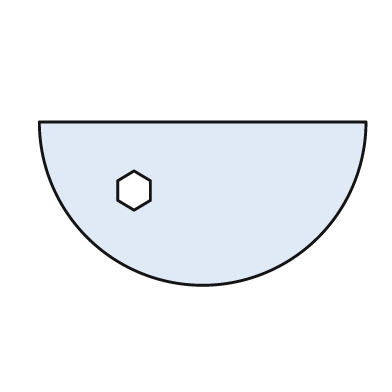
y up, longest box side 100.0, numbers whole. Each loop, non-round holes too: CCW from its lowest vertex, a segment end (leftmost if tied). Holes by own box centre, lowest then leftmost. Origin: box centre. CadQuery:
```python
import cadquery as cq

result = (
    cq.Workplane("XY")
    .moveTo(-50.0, 25.0)
    .threePointArc((0.0, -25.0), (50.0, 25.0))
    .close()
    .moveTo(-21.0, -2.0)
    .lineTo(-16.0, 1.0)
    .lineTo(-16.0, 7.0)
    .lineTo(-21.0, 10.0)
    .lineTo(-26.0, 7.0)
    .lineTo(-26.0, 1.0)
    .close()
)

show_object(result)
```